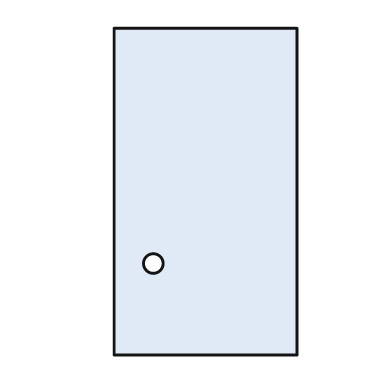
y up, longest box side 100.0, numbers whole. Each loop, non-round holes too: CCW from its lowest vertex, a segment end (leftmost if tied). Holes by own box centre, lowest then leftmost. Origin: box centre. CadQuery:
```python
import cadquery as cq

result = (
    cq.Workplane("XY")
    .moveTo(-28.0, -50.0)
    .lineTo(28.0, -50.0)
    .lineTo(28.0, 50.0)
    .lineTo(-28.0, 50.0)
    .close()
    .moveTo(-16.0, -22.0)
    .circle(3.0)
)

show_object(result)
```